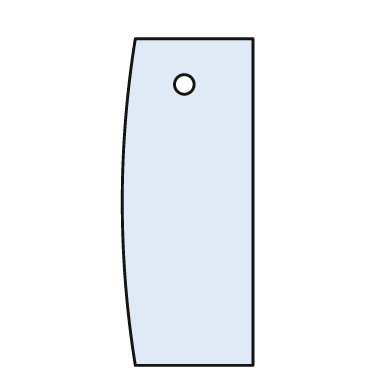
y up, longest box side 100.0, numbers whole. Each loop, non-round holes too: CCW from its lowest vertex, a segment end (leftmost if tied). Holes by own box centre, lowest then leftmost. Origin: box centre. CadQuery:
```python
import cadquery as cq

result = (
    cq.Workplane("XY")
    .moveTo(-16.0, -50.0)
    .lineTo(20.0, -50.0)
    .lineTo(20.0, 50.0)
    .lineTo(-16.0, 50.0)
    .threePointArc((-20.0, 0.0), (-16.0, -50.0))
    .close()
    .moveTo(-1.0, 36.0)
    .circle(3.0)
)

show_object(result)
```